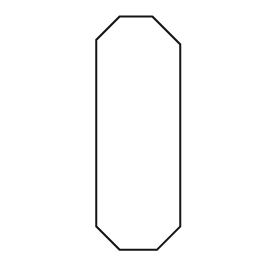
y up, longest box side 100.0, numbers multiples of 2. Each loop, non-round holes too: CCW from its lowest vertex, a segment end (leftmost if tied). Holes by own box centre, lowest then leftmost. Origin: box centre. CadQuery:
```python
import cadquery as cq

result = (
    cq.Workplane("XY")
    .moveTo(-8.0, -50.0)
    .lineTo(8.0, -50.0)
    .lineTo(18.0, -40.0)
    .lineTo(18.0, 38.0)
    .lineTo(6.0, 50.0)
    .lineTo(-8.0, 50.0)
    .lineTo(-18.0, 40.0)
    .lineTo(-18.0, -40.0)
    .close()
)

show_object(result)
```